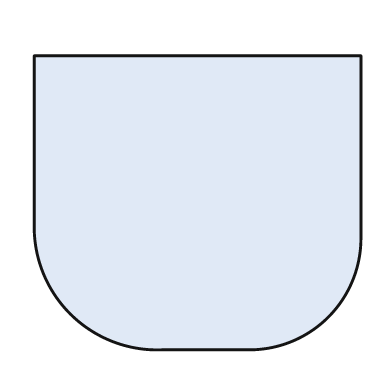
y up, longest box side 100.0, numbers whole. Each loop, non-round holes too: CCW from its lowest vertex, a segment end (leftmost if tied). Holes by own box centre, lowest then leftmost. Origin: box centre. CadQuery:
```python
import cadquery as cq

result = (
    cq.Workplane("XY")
    .moveTo(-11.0, -45.0)
    .lineTo(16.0, -45.0)
    .threePointArc((40.0, -35.0), (50.0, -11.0))
    .lineTo(50.0, 45.0)
    .lineTo(-50.0, 45.0)
    .lineTo(-50.0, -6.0)
    .threePointArc((-39.0, -34.0), (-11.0, -45.0))
    .close()
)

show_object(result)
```